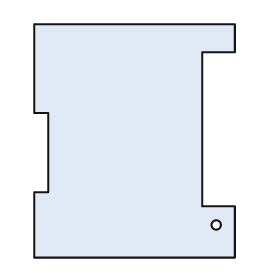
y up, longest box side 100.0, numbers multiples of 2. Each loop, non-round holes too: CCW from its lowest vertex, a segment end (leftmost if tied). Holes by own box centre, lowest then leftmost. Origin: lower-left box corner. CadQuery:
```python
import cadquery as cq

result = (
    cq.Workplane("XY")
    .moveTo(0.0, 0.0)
    .lineTo(86.0, 0.0)
    .lineTo(86.0, 22.0)
    .lineTo(72.0, 22.0)
    .lineTo(72.0, 88.0)
    .lineTo(86.0, 88.0)
    .lineTo(86.0, 100.0)
    .lineTo(0.0, 100.0)
    .lineTo(0.0, 62.0)
    .lineTo(6.0, 62.0)
    .lineTo(6.0, 28.0)
    .lineTo(0.0, 28.0)
    .close()
    .moveTo(78.0, 14.0)
    .circle(2.0)
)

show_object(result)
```